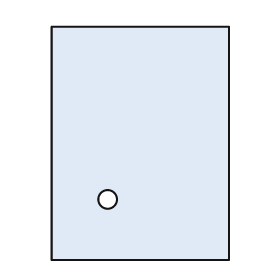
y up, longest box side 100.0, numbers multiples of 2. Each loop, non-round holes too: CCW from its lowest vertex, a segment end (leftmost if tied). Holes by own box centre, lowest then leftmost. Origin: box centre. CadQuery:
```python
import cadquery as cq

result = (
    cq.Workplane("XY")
    .moveTo(-38.0, -50.0)
    .lineTo(38.0, -50.0)
    .lineTo(38.0, 50.0)
    .lineTo(-38.0, 50.0)
    .close()
    .moveTo(-14.0, -24.0)
    .circle(4.0)
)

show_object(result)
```